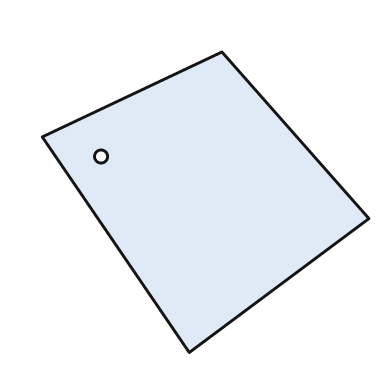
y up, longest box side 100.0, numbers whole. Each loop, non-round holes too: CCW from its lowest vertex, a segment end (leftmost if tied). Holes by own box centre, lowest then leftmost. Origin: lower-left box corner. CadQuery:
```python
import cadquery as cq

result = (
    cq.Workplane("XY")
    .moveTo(45.0, 0.0)
    .lineTo(100.0, 41.0)
    .lineTo(55.0, 92.0)
    .lineTo(0.0, 66.0)
    .close()
    .moveTo(18.0, 60.0)
    .circle(2.0)
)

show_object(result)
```